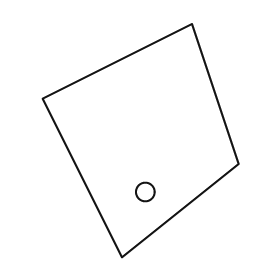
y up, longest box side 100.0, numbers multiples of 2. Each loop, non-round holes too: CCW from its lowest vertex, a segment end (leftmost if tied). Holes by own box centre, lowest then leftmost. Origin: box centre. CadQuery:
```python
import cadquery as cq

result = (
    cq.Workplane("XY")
    .moveTo(-8.0, -50.0)
    .lineTo(42.0, -10.0)
    .lineTo(22.0, 50.0)
    .lineTo(-42.0, 18.0)
    .close()
    .moveTo(2.0, -22.0)
    .circle(4.0)
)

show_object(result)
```